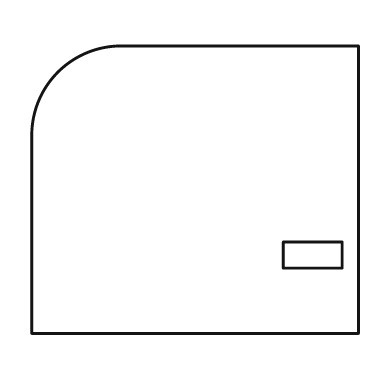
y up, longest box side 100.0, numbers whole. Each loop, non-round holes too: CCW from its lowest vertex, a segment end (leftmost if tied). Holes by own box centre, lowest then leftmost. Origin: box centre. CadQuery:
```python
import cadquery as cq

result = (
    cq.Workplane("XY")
    .moveTo(-50.0, -44.0)
    .lineTo(50.0, -44.0)
    .lineTo(50.0, 44.0)
    .lineTo(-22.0, 44.0)
    .threePointArc((-42.0, 36.0), (-50.0, 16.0))
    .close()
    .moveTo(27.0, -24.0)
    .lineTo(45.0, -24.0)
    .lineTo(45.0, -16.0)
    .lineTo(27.0, -16.0)
    .close()
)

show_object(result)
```